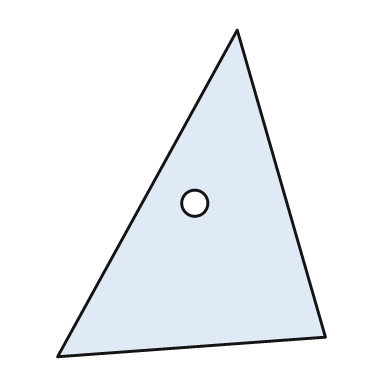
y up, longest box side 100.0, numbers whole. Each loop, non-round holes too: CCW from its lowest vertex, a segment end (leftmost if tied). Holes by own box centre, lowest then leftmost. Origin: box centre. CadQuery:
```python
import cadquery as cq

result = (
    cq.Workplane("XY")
    .moveTo(-41.0, -50.0)
    .lineTo(41.0, -44.0)
    .lineTo(14.0, 50.0)
    .close()
    .moveTo(1.0, -3.0)
    .circle(4.0)
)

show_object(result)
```